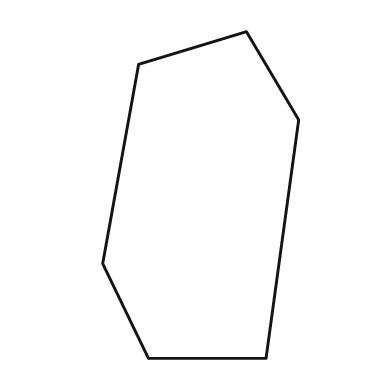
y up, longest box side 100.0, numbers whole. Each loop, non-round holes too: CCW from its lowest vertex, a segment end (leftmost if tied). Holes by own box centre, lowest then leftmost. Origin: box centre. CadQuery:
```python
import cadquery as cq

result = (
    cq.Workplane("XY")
    .moveTo(-16.0, -50.0)
    .lineTo(20.0, -50.0)
    .lineTo(30.0, 23.0)
    .lineTo(14.0, 50.0)
    .lineTo(-19.0, 40.0)
    .lineTo(-30.0, -21.0)
    .close()
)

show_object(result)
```